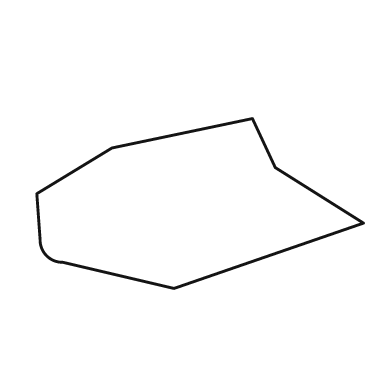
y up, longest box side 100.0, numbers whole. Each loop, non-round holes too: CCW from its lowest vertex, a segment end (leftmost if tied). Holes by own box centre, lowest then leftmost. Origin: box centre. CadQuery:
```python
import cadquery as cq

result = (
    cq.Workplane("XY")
    .moveTo(-8.0, -26.0)
    .lineTo(50.0, -6.0)
    .lineTo(23.0, 11.0)
    .lineTo(16.0, 26.0)
    .lineTo(-27.0, 17.0)
    .lineTo(-50.0, 3.0)
    .lineTo(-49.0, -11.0)
    .threePointArc((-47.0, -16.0), (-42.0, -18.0))
    .close()
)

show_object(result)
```